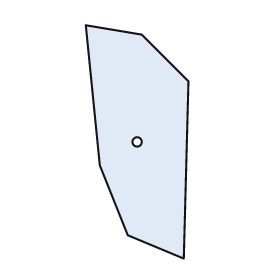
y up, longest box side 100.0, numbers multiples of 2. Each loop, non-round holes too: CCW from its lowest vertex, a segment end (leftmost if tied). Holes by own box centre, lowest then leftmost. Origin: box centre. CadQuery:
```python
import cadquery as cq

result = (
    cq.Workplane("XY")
    .moveTo(20.0, -50.0)
    .lineTo(22.0, 26.0)
    .lineTo(2.0, 46.0)
    .lineTo(-22.0, 50.0)
    .lineTo(-16.0, -10.0)
    .lineTo(-4.0, -40.0)
    .close()
    .moveTo(0.0, 0.0)
    .circle(2.0)
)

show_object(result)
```